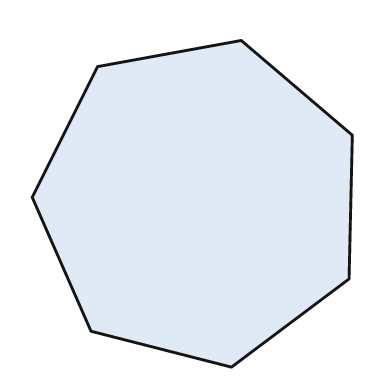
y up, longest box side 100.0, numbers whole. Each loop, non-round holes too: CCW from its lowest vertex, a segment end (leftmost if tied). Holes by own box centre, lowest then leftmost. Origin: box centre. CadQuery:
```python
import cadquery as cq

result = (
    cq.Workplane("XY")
    .moveTo(12.0, -50.0)
    .lineTo(48.0, -23.0)
    .lineTo(49.0, 21.0)
    .lineTo(15.0, 50.0)
    .lineTo(-29.0, 42.0)
    .lineTo(-49.0, 2.0)
    .lineTo(-31.0, -39.0)
    .close()
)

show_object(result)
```